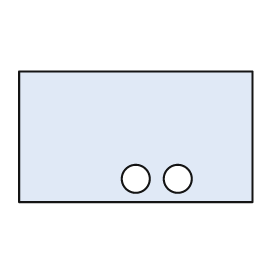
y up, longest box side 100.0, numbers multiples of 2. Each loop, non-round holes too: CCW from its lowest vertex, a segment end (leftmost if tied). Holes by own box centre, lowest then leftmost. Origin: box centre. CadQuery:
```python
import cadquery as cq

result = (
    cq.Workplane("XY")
    .moveTo(-50.0, -28.0)
    .lineTo(50.0, -28.0)
    .lineTo(50.0, 28.0)
    .lineTo(-50.0, 28.0)
    .close()
    .moveTo(0.0, -18.0)
    .circle(6.0)
    .moveTo(18.0, -18.0)
    .circle(6.0)
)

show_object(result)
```